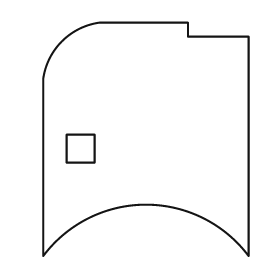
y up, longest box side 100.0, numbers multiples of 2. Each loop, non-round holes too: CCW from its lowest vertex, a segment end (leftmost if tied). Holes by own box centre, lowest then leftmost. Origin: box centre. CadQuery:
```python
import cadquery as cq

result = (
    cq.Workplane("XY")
    .moveTo(-44.0, -50.0)
    .threePointArc((0.0, -28.0), (44.0, -50.0))
    .lineTo(44.0, 44.0)
    .lineTo(18.0, 44.0)
    .lineTo(18.0, 50.0)
    .lineTo(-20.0, 50.0)
    .threePointArc((-36.0, 42.0), (-44.0, 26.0))
    .close()
    .moveTo(-34.0, -10.0)
    .lineTo(-22.0, -10.0)
    .lineTo(-22.0, 2.0)
    .lineTo(-34.0, 2.0)
    .close()
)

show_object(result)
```